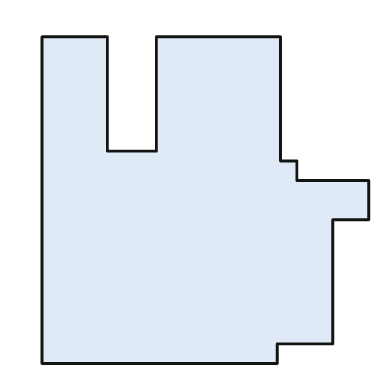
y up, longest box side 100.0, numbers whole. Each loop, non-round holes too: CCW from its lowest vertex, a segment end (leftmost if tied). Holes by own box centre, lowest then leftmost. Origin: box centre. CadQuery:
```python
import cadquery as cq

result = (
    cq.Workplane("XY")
    .moveTo(-50.0, -50.0)
    .lineTo(22.0, -50.0)
    .lineTo(22.0, -44.0)
    .lineTo(39.0, -44.0)
    .lineTo(39.0, -6.0)
    .lineTo(50.0, -6.0)
    .lineTo(50.0, 6.0)
    .lineTo(28.0, 6.0)
    .lineTo(28.0, 12.0)
    .lineTo(23.0, 12.0)
    .lineTo(23.0, 50.0)
    .lineTo(-15.0, 50.0)
    .lineTo(-15.0, 15.0)
    .lineTo(-30.0, 15.0)
    .lineTo(-30.0, 50.0)
    .lineTo(-50.0, 50.0)
    .close()
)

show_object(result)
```